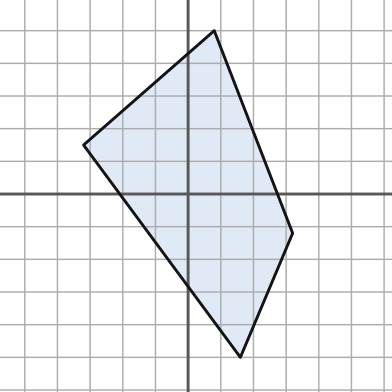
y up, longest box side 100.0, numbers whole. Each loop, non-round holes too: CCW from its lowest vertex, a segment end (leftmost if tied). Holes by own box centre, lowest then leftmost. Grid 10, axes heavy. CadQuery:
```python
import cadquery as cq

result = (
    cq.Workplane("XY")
    .moveTo(16.0, -50.0)
    .lineTo(32.0, -12.0)
    .lineTo(8.0, 50.0)
    .lineTo(-32.0, 15.0)
    .close()
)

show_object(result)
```